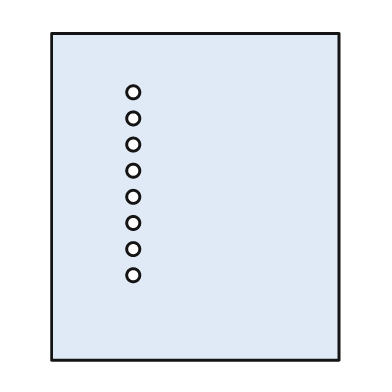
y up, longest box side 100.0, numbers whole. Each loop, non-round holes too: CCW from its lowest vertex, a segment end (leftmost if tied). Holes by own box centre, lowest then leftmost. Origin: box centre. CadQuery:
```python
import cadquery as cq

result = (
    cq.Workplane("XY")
    .moveTo(-44.0, -50.0)
    .lineTo(44.0, -50.0)
    .lineTo(44.0, 50.0)
    .lineTo(-44.0, 50.0)
    .close()
    .moveTo(-19.0, -24.0)
    .circle(2.0)
    .moveTo(-19.0, -16.0)
    .circle(2.0)
    .moveTo(-19.0, -8.0)
    .circle(2.0)
    .moveTo(-19.0, 0.0)
    .circle(2.0)
    .moveTo(-19.0, 8.0)
    .circle(2.0)
    .moveTo(-19.0, 16.0)
    .circle(2.0)
    .moveTo(-19.0, 24.0)
    .circle(2.0)
    .moveTo(-19.0, 32.0)
    .circle(2.0)
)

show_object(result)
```